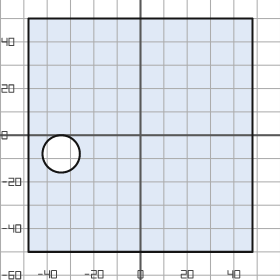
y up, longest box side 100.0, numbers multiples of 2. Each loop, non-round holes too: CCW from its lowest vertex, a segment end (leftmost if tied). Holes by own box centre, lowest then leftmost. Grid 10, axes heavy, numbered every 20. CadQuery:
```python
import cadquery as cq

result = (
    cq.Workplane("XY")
    .moveTo(-48.0, -50.0)
    .lineTo(48.0, -50.0)
    .lineTo(48.0, 50.0)
    .lineTo(-48.0, 50.0)
    .close()
    .moveTo(-34.0, -8.0)
    .circle(8.0)
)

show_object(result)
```